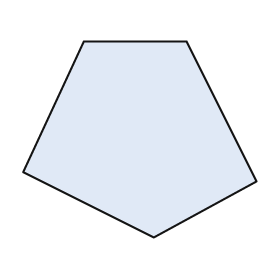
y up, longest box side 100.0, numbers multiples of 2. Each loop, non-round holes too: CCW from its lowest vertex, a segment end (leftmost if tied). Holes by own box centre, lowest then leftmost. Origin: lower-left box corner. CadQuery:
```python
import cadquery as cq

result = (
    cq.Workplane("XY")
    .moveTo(56.0, 0.0)
    .lineTo(100.0, 24.0)
    .lineTo(70.0, 84.0)
    .lineTo(26.0, 84.0)
    .lineTo(0.0, 28.0)
    .close()
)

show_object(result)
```